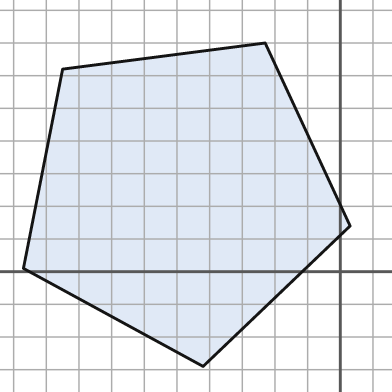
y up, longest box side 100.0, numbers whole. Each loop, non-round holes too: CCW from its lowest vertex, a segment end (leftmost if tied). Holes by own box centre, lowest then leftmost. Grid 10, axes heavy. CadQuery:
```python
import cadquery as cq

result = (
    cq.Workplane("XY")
    .moveTo(-42.0, -29.0)
    .lineTo(3.0, 14.0)
    .lineTo(-23.0, 70.0)
    .lineTo(-85.0, 62.0)
    .lineTo(-97.0, 1.0)
    .close()
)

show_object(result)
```